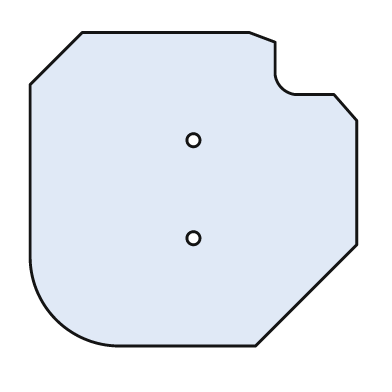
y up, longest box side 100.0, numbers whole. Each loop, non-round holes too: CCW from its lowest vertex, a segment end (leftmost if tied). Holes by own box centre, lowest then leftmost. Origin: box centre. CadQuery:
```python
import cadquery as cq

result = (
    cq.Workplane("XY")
    .moveTo(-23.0, -48.0)
    .lineTo(19.0, -48.0)
    .lineTo(50.0, -17.0)
    .lineTo(50.0, 21.0)
    .lineTo(43.0, 29.0)
    .lineTo(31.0, 29.0)
    .threePointArc((27.0, 31.0), (25.0, 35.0))
    .lineTo(25.0, 45.0)
    .lineTo(17.0, 48.0)
    .lineTo(-34.0, 48.0)
    .lineTo(-50.0, 32.0)
    .lineTo(-50.0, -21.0)
    .threePointArc((-42.0, -40.0), (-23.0, -48.0))
    .close()
    .moveTo(0.0, -15.0)
    .circle(2.0)
    .moveTo(0.0, 15.0)
    .circle(2.0)
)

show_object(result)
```